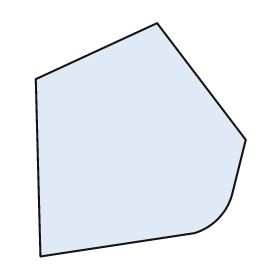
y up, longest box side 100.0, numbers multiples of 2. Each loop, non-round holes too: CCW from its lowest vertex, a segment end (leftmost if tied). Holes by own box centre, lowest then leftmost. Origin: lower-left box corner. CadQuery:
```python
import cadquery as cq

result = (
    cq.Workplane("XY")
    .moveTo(2.0, 0.0)
    .lineTo(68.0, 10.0)
    .threePointArc((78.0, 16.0), (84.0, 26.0))
    .lineTo(90.0, 50.0)
    .lineTo(52.0, 100.0)
    .lineTo(0.0, 76.0)
    .close()
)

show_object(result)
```